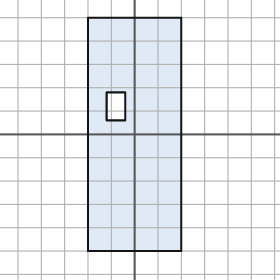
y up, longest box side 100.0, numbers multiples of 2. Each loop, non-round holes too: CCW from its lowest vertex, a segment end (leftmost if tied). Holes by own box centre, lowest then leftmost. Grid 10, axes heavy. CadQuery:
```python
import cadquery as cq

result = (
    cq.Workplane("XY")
    .moveTo(-20.0, -50.0)
    .lineTo(20.0, -50.0)
    .lineTo(20.0, 50.0)
    .lineTo(-20.0, 50.0)
    .close()
    .moveTo(-12.0, 6.0)
    .lineTo(-4.0, 6.0)
    .lineTo(-4.0, 18.0)
    .lineTo(-12.0, 18.0)
    .close()
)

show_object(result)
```